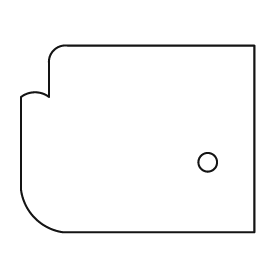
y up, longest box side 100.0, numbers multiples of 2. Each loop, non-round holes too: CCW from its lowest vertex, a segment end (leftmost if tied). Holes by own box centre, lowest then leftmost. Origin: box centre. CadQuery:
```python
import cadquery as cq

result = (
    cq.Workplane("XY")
    .moveTo(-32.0, -40.0)
    .lineTo(50.0, -40.0)
    .lineTo(50.0, 40.0)
    .lineTo(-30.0, 40.0)
    .threePointArc((-36.0, 38.0), (-38.0, 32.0))
    .lineTo(-38.0, 18.0)
    .threePointArc((-44.0, 20.0), (-50.0, 18.0))
    .lineTo(-50.0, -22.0)
    .threePointArc((-44.0, -34.0), (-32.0, -40.0))
    .close()
    .moveTo(30.0, -10.0)
    .circle(4.0)
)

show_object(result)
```